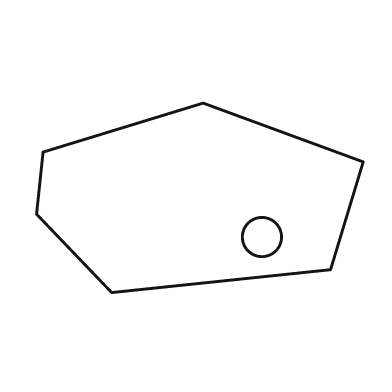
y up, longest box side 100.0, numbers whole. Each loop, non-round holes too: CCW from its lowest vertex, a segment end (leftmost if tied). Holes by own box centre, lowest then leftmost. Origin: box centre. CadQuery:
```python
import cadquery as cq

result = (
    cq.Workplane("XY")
    .moveTo(-27.0, -29.0)
    .lineTo(40.0, -22.0)
    .lineTo(50.0, 11.0)
    .lineTo(1.0, 29.0)
    .lineTo(-48.0, 14.0)
    .lineTo(-50.0, -5.0)
    .close()
    .moveTo(19.0, -12.0)
    .circle(6.0)
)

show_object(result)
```